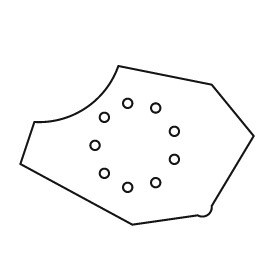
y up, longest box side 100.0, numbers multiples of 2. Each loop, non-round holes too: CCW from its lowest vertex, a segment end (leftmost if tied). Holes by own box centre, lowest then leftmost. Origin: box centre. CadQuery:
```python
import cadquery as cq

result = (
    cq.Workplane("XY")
    .moveTo(-2.0, -34.0)
    .lineTo(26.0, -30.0)
    .threePointArc((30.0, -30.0), (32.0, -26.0))
    .lineTo(50.0, 4.0)
    .lineTo(32.0, 26.0)
    .lineTo(-8.0, 34.0)
    .threePointArc((-22.0, 16.0), (-44.0, 10.0))
    .lineTo(-50.0, -8.0)
    .close()
    .moveTo(-4.0, -18.0)
    .circle(2.0)
    .moveTo(8.0, -16.0)
    .circle(2.0)
    .moveTo(-14.0, -12.0)
    .circle(2.0)
    .moveTo(16.0, -6.0)
    .circle(2.0)
    .moveTo(-18.0, 0.0)
    .circle(2.0)
    .moveTo(16.0, 6.0)
    .circle(2.0)
    .moveTo(-14.0, 12.0)
    .circle(2.0)
    .moveTo(8.0, 16.0)
    .circle(2.0)
    .moveTo(-4.0, 18.0)
    .circle(2.0)
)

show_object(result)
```